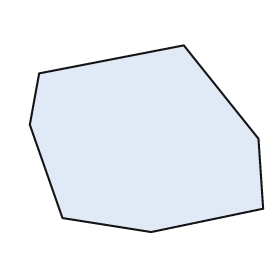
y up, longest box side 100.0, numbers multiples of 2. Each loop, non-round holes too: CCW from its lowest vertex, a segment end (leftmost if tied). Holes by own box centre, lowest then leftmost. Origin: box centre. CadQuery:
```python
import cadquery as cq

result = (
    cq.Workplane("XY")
    .moveTo(2.0, -40.0)
    .lineTo(50.0, -30.0)
    .lineTo(48.0, 0.0)
    .lineTo(16.0, 40.0)
    .lineTo(-46.0, 28.0)
    .lineTo(-50.0, 6.0)
    .lineTo(-36.0, -34.0)
    .close()
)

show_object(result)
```